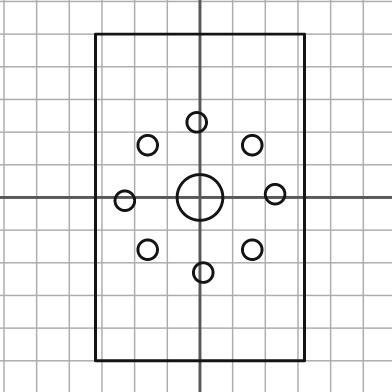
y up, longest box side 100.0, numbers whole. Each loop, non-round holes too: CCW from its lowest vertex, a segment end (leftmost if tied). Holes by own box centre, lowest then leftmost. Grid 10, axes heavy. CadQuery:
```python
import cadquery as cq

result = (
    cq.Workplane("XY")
    .moveTo(-32.0, -50.0)
    .lineTo(32.0, -50.0)
    .lineTo(32.0, 50.0)
    .lineTo(-32.0, 50.0)
    .close()
    .moveTo(1.0, -23.0)
    .circle(3.0)
    .moveTo(-16.0, -16.0)
    .circle(3.0)
    .moveTo(16.0, -16.0)
    .circle(3.0)
    .moveTo(-23.0, -1.0)
    .circle(3.0)
    .moveTo(0.0, 0.0)
    .circle(7.0)
    .moveTo(23.0, 1.0)
    .circle(3.0)
    .moveTo(-16.0, 16.0)
    .circle(3.0)
    .moveTo(16.0, 16.0)
    .circle(3.0)
    .moveTo(-1.0, 23.0)
    .circle(3.0)
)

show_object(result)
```